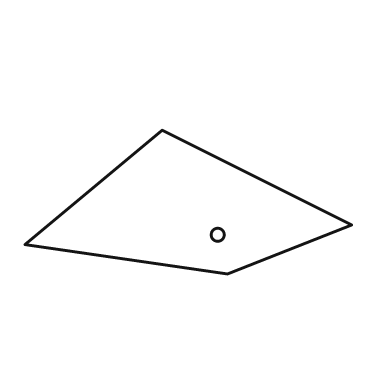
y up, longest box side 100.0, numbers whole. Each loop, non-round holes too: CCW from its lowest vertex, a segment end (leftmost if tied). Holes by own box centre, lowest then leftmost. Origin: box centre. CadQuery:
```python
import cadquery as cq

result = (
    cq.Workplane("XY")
    .moveTo(12.0, -22.0)
    .lineTo(50.0, -7.0)
    .lineTo(-8.0, 22.0)
    .lineTo(-50.0, -13.0)
    .close()
    .moveTo(9.0, -10.0)
    .circle(2.0)
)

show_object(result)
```